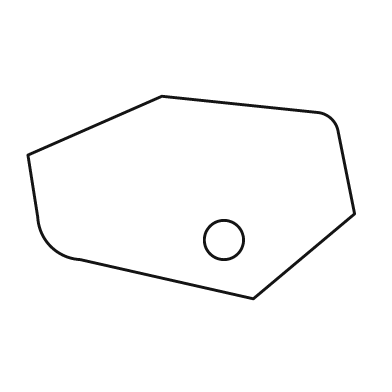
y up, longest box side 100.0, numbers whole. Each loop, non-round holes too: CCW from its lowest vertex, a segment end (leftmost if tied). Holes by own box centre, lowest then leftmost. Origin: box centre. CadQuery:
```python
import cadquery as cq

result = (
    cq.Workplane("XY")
    .moveTo(19.0, -31.0)
    .lineTo(50.0, -5.0)
    .lineTo(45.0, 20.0)
    .threePointArc((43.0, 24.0), (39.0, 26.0))
    .lineTo(-9.0, 31.0)
    .lineTo(-50.0, 13.0)
    .lineTo(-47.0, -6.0)
    .threePointArc((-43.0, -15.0), (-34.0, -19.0))
    .close()
    .moveTo(10.0, -13.0)
    .circle(6.0)
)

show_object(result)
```